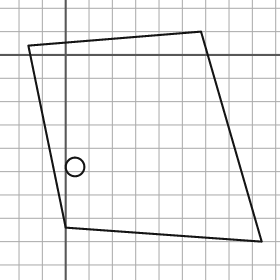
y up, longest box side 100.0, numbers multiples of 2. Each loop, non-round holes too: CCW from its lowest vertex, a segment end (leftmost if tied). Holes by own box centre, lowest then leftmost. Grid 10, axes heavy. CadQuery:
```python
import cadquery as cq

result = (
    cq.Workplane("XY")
    .moveTo(84.0, -80.0)
    .lineTo(58.0, 10.0)
    .lineTo(-16.0, 4.0)
    .lineTo(0.0, -74.0)
    .close()
    .moveTo(4.0, -48.0)
    .circle(4.0)
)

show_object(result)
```